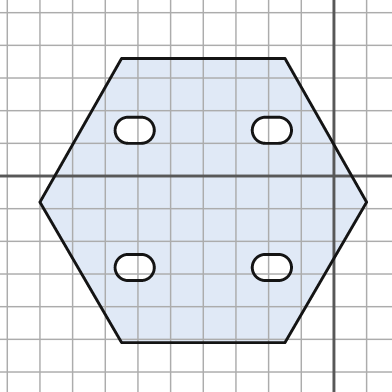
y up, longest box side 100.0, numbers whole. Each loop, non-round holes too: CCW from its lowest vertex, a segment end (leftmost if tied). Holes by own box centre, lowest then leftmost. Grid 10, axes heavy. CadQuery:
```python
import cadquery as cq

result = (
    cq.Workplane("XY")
    .moveTo(-65.0, -51.0)
    .lineTo(-15.0, -51.0)
    .lineTo(10.0, -8.0)
    .lineTo(-15.0, 36.0)
    .lineTo(-65.0, 36.0)
    .lineTo(-90.0, -8.0)
    .close()
    .moveTo(-63.0, -32.0)
    .lineTo(-59.0, -32.0)
    .threePointArc((-55.0, -28.0), (-59.0, -24.0))
    .lineTo(-63.0, -24.0)
    .threePointArc((-67.0, -28.0), (-63.0, -32.0))
    .close()
    .moveTo(-21.0, -32.0)
    .lineTo(-17.0, -32.0)
    .threePointArc((-13.0, -28.0), (-17.0, -24.0))
    .lineTo(-21.0, -24.0)
    .threePointArc((-25.0, -28.0), (-21.0, -32.0))
    .close()
    .moveTo(-63.0, 10.0)
    .lineTo(-59.0, 10.0)
    .threePointArc((-55.0, 14.0), (-59.0, 18.0))
    .lineTo(-63.0, 18.0)
    .threePointArc((-67.0, 14.0), (-63.0, 10.0))
    .close()
    .moveTo(-21.0, 10.0)
    .lineTo(-17.0, 10.0)
    .threePointArc((-13.0, 14.0), (-17.0, 18.0))
    .lineTo(-21.0, 18.0)
    .threePointArc((-25.0, 14.0), (-21.0, 10.0))
    .close()
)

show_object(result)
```